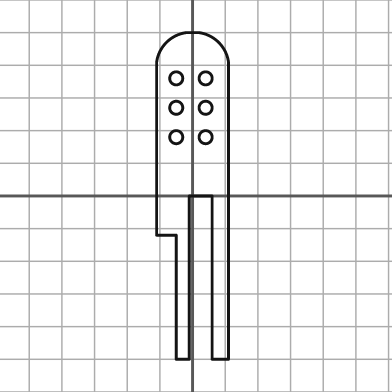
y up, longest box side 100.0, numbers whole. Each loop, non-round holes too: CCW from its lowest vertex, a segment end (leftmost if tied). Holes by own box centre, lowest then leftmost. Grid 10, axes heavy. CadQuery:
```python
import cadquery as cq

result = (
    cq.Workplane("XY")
    .moveTo(-5.0, -50.0)
    .lineTo(-1.0, -50.0)
    .lineTo(-1.0, 0.0)
    .lineTo(6.0, 0.0)
    .lineTo(6.0, -50.0)
    .lineTo(11.0, -50.0)
    .lineTo(11.0, 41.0)
    .threePointArc((8.0, 47.0), (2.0, 50.0))
    .lineTo(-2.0, 50.0)
    .threePointArc((-8.0, 47.0), (-11.0, 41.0))
    .lineTo(-11.0, -12.0)
    .lineTo(-5.0, -12.0)
    .close()
    .moveTo(-5.0, 18.0)
    .circle(2.0)
    .moveTo(4.0, 18.0)
    .circle(2.0)
    .moveTo(-5.0, 27.0)
    .circle(2.0)
    .moveTo(4.0, 27.0)
    .circle(2.0)
    .moveTo(-5.0, 36.0)
    .circle(2.0)
    .moveTo(4.0, 36.0)
    .circle(2.0)
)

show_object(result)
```